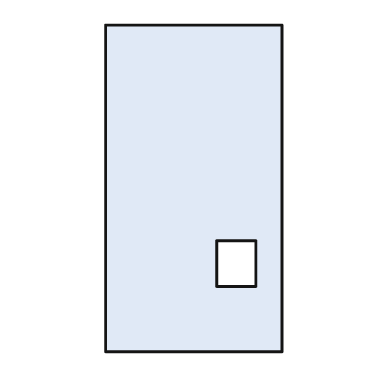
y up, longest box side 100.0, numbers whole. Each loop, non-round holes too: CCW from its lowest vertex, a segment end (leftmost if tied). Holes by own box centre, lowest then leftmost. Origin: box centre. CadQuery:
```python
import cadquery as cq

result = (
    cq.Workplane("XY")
    .moveTo(-27.0, -50.0)
    .lineTo(27.0, -50.0)
    .lineTo(27.0, 50.0)
    .lineTo(-27.0, 50.0)
    .close()
    .moveTo(7.0, -30.0)
    .lineTo(19.0, -30.0)
    .lineTo(19.0, -16.0)
    .lineTo(7.0, -16.0)
    .close()
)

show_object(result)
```